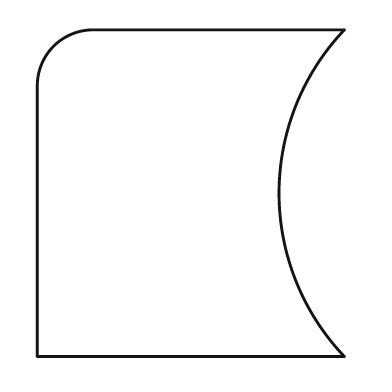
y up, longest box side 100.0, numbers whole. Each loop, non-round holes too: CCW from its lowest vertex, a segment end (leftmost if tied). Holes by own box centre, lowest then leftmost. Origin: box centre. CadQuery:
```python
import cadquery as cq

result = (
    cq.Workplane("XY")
    .moveTo(-47.0, -50.0)
    .lineTo(47.0, -50.0)
    .threePointArc((27.0, 0.0), (47.0, 50.0))
    .lineTo(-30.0, 50.0)
    .threePointArc((-42.0, 45.0), (-47.0, 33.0))
    .close()
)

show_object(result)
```